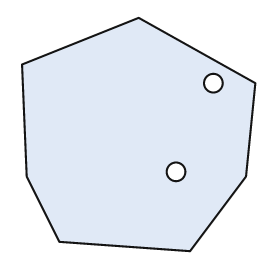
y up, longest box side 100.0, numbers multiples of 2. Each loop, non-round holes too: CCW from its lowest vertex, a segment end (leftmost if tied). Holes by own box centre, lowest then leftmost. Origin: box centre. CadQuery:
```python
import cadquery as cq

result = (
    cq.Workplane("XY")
    .moveTo(22.0, -50.0)
    .lineTo(46.0, -18.0)
    .lineTo(50.0, 22.0)
    .lineTo(0.0, 50.0)
    .lineTo(-50.0, 30.0)
    .lineTo(-48.0, -18.0)
    .lineTo(-34.0, -46.0)
    .close()
    .moveTo(16.0, -16.0)
    .circle(4.0)
    .moveTo(32.0, 22.0)
    .circle(4.0)
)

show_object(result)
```